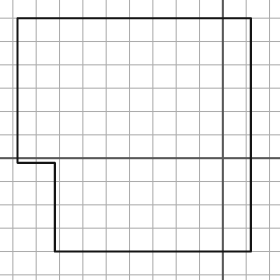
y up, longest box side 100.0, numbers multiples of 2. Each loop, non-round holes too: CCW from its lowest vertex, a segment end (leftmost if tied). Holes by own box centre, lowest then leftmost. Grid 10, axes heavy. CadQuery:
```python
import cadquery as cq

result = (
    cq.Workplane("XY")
    .moveTo(-72.0, -40.0)
    .lineTo(12.0, -40.0)
    .lineTo(12.0, 60.0)
    .lineTo(-88.0, 60.0)
    .lineTo(-88.0, -2.0)
    .lineTo(-72.0, -2.0)
    .close()
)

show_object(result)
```